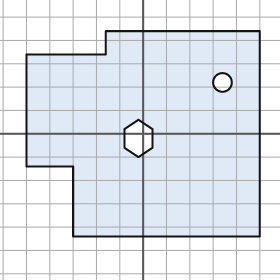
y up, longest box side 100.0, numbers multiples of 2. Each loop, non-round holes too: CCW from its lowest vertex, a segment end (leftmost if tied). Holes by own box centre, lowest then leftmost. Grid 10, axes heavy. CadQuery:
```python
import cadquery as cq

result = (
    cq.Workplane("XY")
    .moveTo(-30.0, -44.0)
    .lineTo(50.0, -44.0)
    .lineTo(50.0, 44.0)
    .lineTo(-16.0, 44.0)
    .lineTo(-16.0, 34.0)
    .lineTo(-50.0, 34.0)
    .lineTo(-50.0, -14.0)
    .lineTo(-30.0, -14.0)
    .close()
    .moveTo(-2.0, -10.0)
    .lineTo(4.0, -6.0)
    .lineTo(4.0, 2.0)
    .lineTo(-2.0, 6.0)
    .lineTo(-8.0, 2.0)
    .lineTo(-8.0, -6.0)
    .close()
    .moveTo(34.0, 22.0)
    .circle(4.0)
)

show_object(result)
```